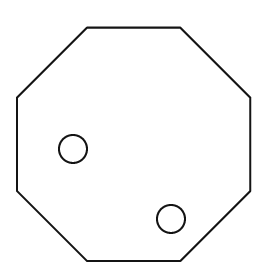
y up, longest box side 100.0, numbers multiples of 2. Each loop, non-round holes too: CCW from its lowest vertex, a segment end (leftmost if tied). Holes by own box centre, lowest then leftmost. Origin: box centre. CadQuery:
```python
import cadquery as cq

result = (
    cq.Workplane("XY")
    .moveTo(-20.0, -50.0)
    .lineTo(20.0, -50.0)
    .lineTo(50.0, -20.0)
    .lineTo(50.0, 20.0)
    .lineTo(20.0, 50.0)
    .lineTo(-20.0, 50.0)
    .lineTo(-50.0, 20.0)
    .lineTo(-50.0, -20.0)
    .close()
    .moveTo(16.0, -32.0)
    .circle(6.0)
    .moveTo(-26.0, -2.0)
    .circle(6.0)
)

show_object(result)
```